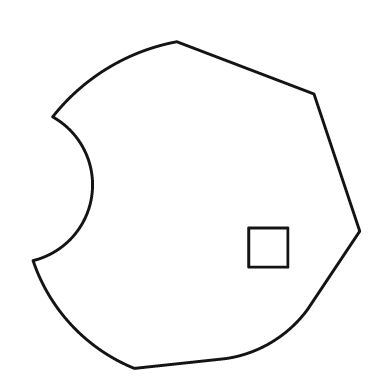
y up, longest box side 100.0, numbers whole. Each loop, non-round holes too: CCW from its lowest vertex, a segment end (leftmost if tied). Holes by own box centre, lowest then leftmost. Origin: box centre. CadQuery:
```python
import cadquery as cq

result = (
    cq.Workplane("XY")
    .moveTo(-19.0, -50.0)
    .lineTo(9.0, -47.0)
    .threePointArc((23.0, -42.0), (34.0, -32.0))
    .lineTo(50.0, -8.0)
    .lineTo(36.0, 34.0)
    .lineTo(-6.0, 50.0)
    .threePointArc((-27.0, 42.0), (-44.0, 27.0))
    .threePointArc((-32.0, 3.0), (-50.0, -17.0))
    .threePointArc((-38.0, -37.0), (-19.0, -50.0))
    .close()
    .moveTo(16.0, -19.0)
    .lineTo(28.0, -19.0)
    .lineTo(28.0, -7.0)
    .lineTo(16.0, -7.0)
    .close()
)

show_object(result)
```